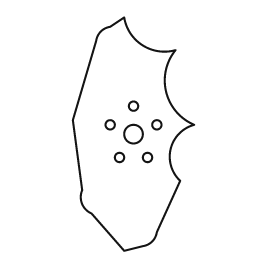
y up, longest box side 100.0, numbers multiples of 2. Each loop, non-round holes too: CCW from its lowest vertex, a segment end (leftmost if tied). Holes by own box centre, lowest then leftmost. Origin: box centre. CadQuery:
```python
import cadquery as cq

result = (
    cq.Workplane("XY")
    .moveTo(-4.0, -50.0)
    .lineTo(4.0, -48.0)
    .threePointArc((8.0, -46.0), (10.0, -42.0))
    .lineTo(20.0, -20.0)
    .threePointArc((16.0, -6.0), (26.0, 4.0))
    .threePointArc((14.0, 18.0), (18.0, 36.0))
    .threePointArc((4.0, 38.0), (-4.0, 50.0))
    .lineTo(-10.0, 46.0)
    .threePointArc((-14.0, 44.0), (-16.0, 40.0))
    .lineTo(-26.0, 6.0)
    .lineTo(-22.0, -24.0)
    .threePointArc((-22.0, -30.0), (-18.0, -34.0))
    .close()
    .moveTo(-6.0, -10.0)
    .circle(2.0)
    .moveTo(6.0, -10.0)
    .circle(2.0)
    .moveTo(0.0, 0.0)
    .circle(4.0)
    .moveTo(-10.0, 4.0)
    .circle(2.0)
    .moveTo(10.0, 4.0)
    .circle(2.0)
    .moveTo(0.0, 12.0)
    .circle(2.0)
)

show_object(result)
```